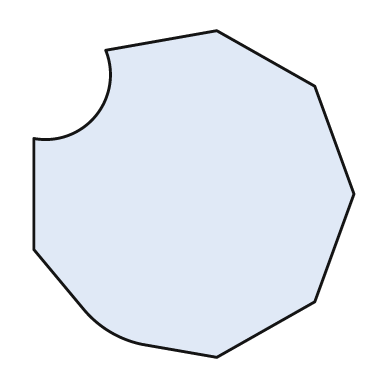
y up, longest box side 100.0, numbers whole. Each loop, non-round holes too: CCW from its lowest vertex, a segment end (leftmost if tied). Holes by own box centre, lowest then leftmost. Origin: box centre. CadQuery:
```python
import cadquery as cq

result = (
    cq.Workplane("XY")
    .moveTo(7.0, -50.0)
    .lineTo(37.0, -33.0)
    .lineTo(49.0, 0.0)
    .lineTo(37.0, 33.0)
    .lineTo(7.0, 50.0)
    .lineTo(-27.0, 44.0)
    .threePointArc((-30.0, 24.0), (-49.0, 17.0))
    .lineTo(-49.0, -17.0)
    .lineTo(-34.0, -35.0)
    .threePointArc((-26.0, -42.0), (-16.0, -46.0))
    .close()
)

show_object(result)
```